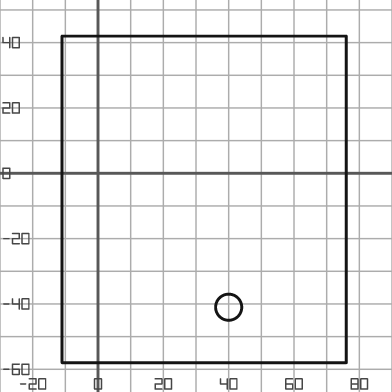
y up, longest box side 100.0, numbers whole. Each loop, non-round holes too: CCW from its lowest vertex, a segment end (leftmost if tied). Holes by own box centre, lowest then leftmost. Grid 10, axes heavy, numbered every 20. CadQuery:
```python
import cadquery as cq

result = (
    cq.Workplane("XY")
    .moveTo(-11.0, -58.0)
    .lineTo(76.0, -58.0)
    .lineTo(76.0, 42.0)
    .lineTo(-11.0, 42.0)
    .close()
    .moveTo(40.0, -41.0)
    .circle(4.0)
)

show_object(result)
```